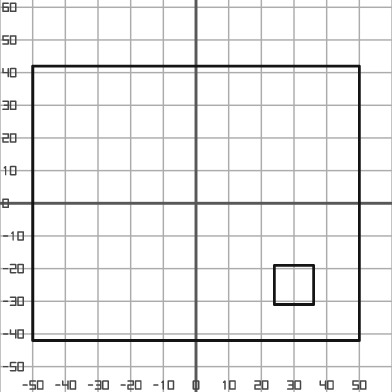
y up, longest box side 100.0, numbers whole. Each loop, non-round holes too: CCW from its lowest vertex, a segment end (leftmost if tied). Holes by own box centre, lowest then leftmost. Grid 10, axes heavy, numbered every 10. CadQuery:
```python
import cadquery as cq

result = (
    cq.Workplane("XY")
    .moveTo(-50.0, -42.0)
    .lineTo(50.0, -42.0)
    .lineTo(50.0, 42.0)
    .lineTo(-50.0, 42.0)
    .close()
    .moveTo(24.0, -31.0)
    .lineTo(36.0, -31.0)
    .lineTo(36.0, -19.0)
    .lineTo(24.0, -19.0)
    .close()
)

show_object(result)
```